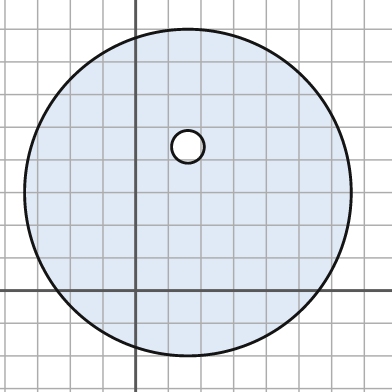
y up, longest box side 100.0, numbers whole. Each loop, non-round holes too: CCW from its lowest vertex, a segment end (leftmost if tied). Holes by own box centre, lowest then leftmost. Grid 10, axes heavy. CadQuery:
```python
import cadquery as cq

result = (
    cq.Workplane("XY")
    .moveTo(16.0, 30.0)
    .circle(50.0)
    .moveTo(16.0, 44.0)
    .circle(5.0)
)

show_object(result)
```